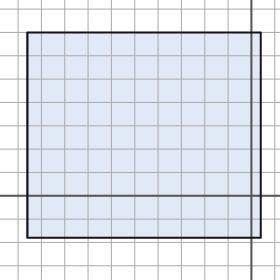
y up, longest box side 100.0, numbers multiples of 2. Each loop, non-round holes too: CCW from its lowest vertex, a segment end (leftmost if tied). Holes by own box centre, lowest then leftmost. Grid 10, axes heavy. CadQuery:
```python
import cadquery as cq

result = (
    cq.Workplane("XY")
    .moveTo(-96.0, -18.0)
    .lineTo(4.0, -18.0)
    .lineTo(4.0, 70.0)
    .lineTo(-96.0, 70.0)
    .close()
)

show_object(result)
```